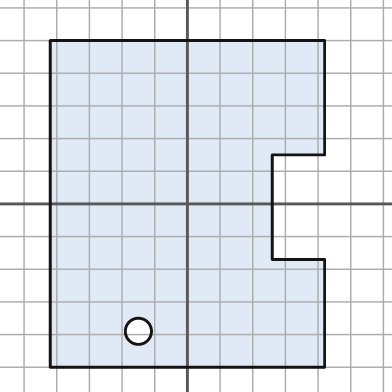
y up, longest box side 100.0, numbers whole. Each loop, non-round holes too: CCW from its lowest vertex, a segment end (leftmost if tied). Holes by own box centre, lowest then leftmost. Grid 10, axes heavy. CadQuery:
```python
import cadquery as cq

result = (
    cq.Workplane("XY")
    .moveTo(-42.0, -50.0)
    .lineTo(42.0, -50.0)
    .lineTo(42.0, -17.0)
    .lineTo(26.0, -17.0)
    .lineTo(26.0, 15.0)
    .lineTo(42.0, 15.0)
    .lineTo(42.0, 50.0)
    .lineTo(-42.0, 50.0)
    .close()
    .moveTo(-15.0, -39.0)
    .circle(4.0)
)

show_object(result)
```